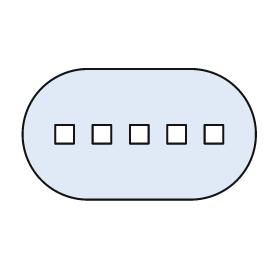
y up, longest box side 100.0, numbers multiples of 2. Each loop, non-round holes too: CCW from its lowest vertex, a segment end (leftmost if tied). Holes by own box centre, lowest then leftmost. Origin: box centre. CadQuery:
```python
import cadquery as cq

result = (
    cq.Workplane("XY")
    .moveTo(-22.0, -28.0)
    .lineTo(22.0, -28.0)
    .threePointArc((50.0, 0.0), (22.0, 28.0))
    .lineTo(-22.0, 28.0)
    .threePointArc((-50.0, 0.0), (-22.0, -28.0))
    .close()
    .moveTo(-36.0, -4.0)
    .lineTo(-28.0, -4.0)
    .lineTo(-28.0, 4.0)
    .lineTo(-36.0, 4.0)
    .close()
    .moveTo(-20.0, -4.0)
    .lineTo(-12.0, -4.0)
    .lineTo(-12.0, 4.0)
    .lineTo(-20.0, 4.0)
    .close()
    .moveTo(-4.0, -4.0)
    .lineTo(4.0, -4.0)
    .lineTo(4.0, 4.0)
    .lineTo(-4.0, 4.0)
    .close()
    .moveTo(12.0, -4.0)
    .lineTo(20.0, -4.0)
    .lineTo(20.0, 4.0)
    .lineTo(12.0, 4.0)
    .close()
    .moveTo(28.0, -4.0)
    .lineTo(36.0, -4.0)
    .lineTo(36.0, 4.0)
    .lineTo(28.0, 4.0)
    .close()
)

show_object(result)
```